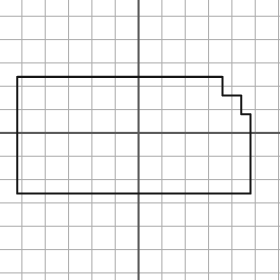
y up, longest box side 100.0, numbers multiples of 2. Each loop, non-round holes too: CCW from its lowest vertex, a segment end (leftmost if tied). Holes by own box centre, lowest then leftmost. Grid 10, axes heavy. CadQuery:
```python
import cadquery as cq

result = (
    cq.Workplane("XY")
    .moveTo(-52.0, -26.0)
    .lineTo(48.0, -26.0)
    .lineTo(48.0, 8.0)
    .lineTo(44.0, 8.0)
    .lineTo(44.0, 16.0)
    .lineTo(36.0, 16.0)
    .lineTo(36.0, 24.0)
    .lineTo(-52.0, 24.0)
    .close()
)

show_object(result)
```